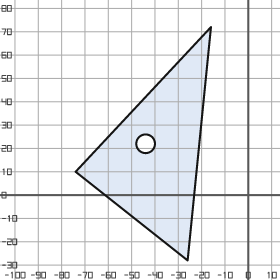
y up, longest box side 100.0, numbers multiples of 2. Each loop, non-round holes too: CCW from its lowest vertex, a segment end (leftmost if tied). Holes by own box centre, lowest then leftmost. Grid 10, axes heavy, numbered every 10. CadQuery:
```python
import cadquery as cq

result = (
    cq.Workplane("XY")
    .moveTo(-26.0, -28.0)
    .lineTo(-16.0, 72.0)
    .lineTo(-74.0, 10.0)
    .close()
    .moveTo(-44.0, 22.0)
    .circle(4.0)
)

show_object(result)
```